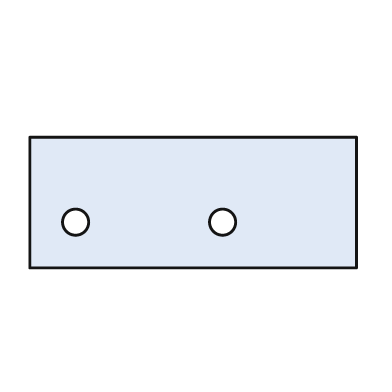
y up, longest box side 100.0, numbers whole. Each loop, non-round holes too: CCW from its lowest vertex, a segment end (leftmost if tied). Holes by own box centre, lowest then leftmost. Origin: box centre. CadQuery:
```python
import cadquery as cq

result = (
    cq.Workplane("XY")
    .moveTo(-50.0, -20.0)
    .lineTo(50.0, -20.0)
    .lineTo(50.0, 20.0)
    .lineTo(-50.0, 20.0)
    .close()
    .moveTo(-36.0, -6.0)
    .circle(4.0)
    .moveTo(9.0, -6.0)
    .circle(4.0)
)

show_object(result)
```